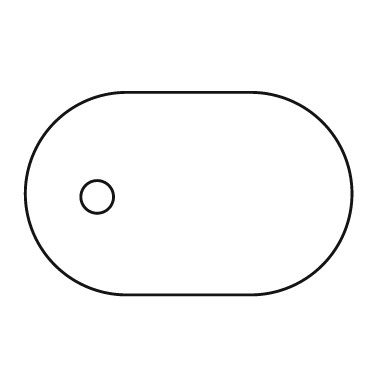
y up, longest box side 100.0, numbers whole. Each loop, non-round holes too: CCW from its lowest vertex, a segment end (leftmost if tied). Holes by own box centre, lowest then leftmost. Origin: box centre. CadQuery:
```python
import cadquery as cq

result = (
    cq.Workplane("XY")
    .moveTo(-19.0, -31.0)
    .lineTo(19.0, -31.0)
    .threePointArc((50.0, 0.0), (19.0, 31.0))
    .lineTo(-19.0, 31.0)
    .threePointArc((-50.0, 0.0), (-19.0, -31.0))
    .close()
    .moveTo(-28.0, -1.0)
    .circle(5.0)
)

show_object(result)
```